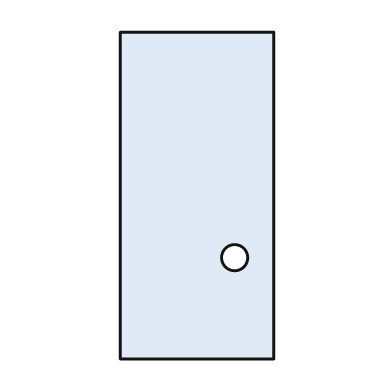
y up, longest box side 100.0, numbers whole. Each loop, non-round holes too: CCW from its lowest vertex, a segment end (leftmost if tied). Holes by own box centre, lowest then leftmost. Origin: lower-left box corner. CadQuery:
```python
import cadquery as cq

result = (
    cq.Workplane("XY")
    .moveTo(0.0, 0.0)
    .lineTo(47.0, 0.0)
    .lineTo(47.0, 100.0)
    .lineTo(0.0, 100.0)
    .close()
    .moveTo(35.0, 31.0)
    .circle(4.0)
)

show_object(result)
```